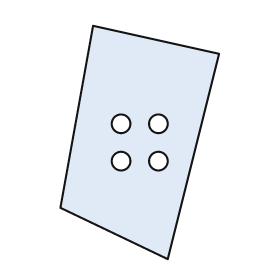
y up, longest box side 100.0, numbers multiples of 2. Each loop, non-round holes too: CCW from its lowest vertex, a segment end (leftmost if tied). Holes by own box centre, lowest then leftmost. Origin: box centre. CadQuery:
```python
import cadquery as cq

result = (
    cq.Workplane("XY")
    .moveTo(12.0, -50.0)
    .lineTo(34.0, 38.0)
    .lineTo(-20.0, 50.0)
    .lineTo(-34.0, -28.0)
    .close()
    .moveTo(-8.0, -8.0)
    .circle(4.0)
    .moveTo(8.0, -8.0)
    .circle(4.0)
    .moveTo(-8.0, 8.0)
    .circle(4.0)
    .moveTo(8.0, 8.0)
    .circle(4.0)
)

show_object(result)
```